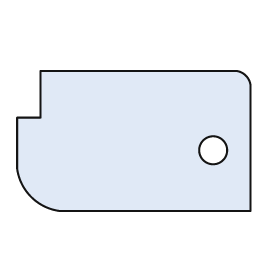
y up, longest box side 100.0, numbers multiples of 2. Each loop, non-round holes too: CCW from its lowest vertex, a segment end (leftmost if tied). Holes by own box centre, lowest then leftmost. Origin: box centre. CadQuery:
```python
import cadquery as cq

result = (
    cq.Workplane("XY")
    .moveTo(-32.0, -30.0)
    .lineTo(50.0, -30.0)
    .lineTo(50.0, 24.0)
    .threePointArc((48.0, 28.0), (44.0, 30.0))
    .lineTo(-40.0, 30.0)
    .lineTo(-40.0, 10.0)
    .lineTo(-50.0, 10.0)
    .lineTo(-50.0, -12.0)
    .threePointArc((-44.0, -24.0), (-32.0, -30.0))
    .close()
    .moveTo(34.0, -4.0)
    .circle(6.0)
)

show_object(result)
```